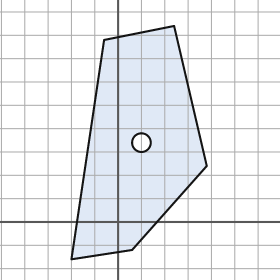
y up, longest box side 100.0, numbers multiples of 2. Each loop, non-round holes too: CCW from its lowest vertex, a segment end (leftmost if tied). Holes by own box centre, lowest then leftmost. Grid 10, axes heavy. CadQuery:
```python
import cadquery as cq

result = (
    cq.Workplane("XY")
    .moveTo(-20.0, -16.0)
    .lineTo(6.0, -12.0)
    .lineTo(38.0, 24.0)
    .lineTo(24.0, 84.0)
    .lineTo(-6.0, 78.0)
    .close()
    .moveTo(10.0, 34.0)
    .circle(4.0)
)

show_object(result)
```